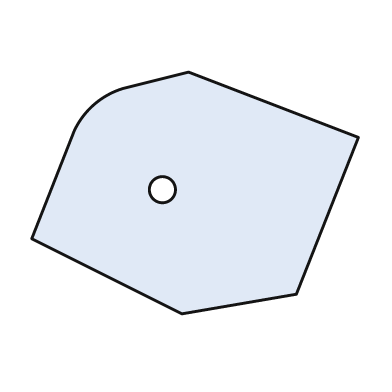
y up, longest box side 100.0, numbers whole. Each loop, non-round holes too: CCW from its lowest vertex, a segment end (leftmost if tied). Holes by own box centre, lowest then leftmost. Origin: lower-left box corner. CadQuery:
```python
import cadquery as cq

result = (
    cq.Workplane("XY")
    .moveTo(46.0, 0.0)
    .lineTo(81.0, 6.0)
    .lineTo(100.0, 54.0)
    .lineTo(48.0, 74.0)
    .lineTo(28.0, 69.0)
    .threePointArc((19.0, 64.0), (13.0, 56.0))
    .lineTo(0.0, 23.0)
    .close()
    .moveTo(40.0, 38.0)
    .circle(4.0)
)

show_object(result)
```